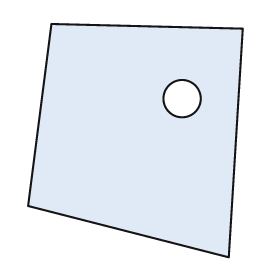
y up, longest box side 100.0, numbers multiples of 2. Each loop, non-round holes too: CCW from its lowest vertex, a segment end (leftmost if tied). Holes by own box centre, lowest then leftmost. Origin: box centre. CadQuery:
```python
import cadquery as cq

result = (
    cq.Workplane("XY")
    .moveTo(40.0, -50.0)
    .lineTo(46.0, 48.0)
    .lineTo(-36.0, 50.0)
    .lineTo(-46.0, -28.0)
    .close()
    .moveTo(20.0, 18.0)
    .circle(8.0)
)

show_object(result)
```